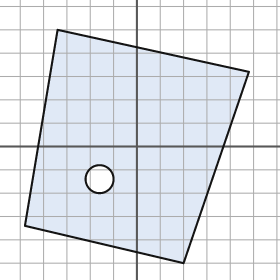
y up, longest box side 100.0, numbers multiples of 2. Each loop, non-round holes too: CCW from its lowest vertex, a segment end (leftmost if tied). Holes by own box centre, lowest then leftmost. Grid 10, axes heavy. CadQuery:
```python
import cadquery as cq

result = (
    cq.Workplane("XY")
    .moveTo(20.0, -50.0)
    .lineTo(48.0, 32.0)
    .lineTo(-34.0, 50.0)
    .lineTo(-48.0, -34.0)
    .close()
    .moveTo(-16.0, -14.0)
    .circle(6.0)
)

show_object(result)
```